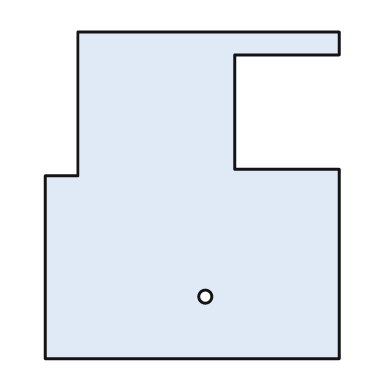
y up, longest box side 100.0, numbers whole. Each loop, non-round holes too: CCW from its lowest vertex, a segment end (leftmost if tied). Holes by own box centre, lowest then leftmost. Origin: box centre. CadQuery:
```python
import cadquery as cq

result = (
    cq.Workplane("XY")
    .moveTo(-45.0, -50.0)
    .lineTo(45.0, -50.0)
    .lineTo(45.0, 8.0)
    .lineTo(13.0, 8.0)
    .lineTo(13.0, 43.0)
    .lineTo(45.0, 43.0)
    .lineTo(45.0, 50.0)
    .lineTo(-35.0, 50.0)
    .lineTo(-35.0, 6.0)
    .lineTo(-45.0, 6.0)
    .close()
    .moveTo(4.0, -31.0)
    .circle(2.0)
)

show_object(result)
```